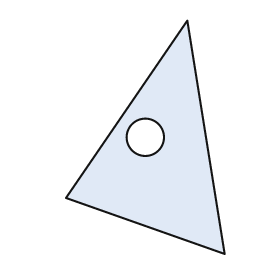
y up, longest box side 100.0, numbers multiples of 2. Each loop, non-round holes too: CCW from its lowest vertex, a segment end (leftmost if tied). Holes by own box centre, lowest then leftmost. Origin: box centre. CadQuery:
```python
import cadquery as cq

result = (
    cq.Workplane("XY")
    .moveTo(34.0, -50.0)
    .lineTo(18.0, 50.0)
    .lineTo(-34.0, -26.0)
    .close()
    .moveTo(0.0, 0.0)
    .circle(8.0)
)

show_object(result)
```